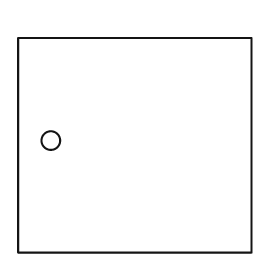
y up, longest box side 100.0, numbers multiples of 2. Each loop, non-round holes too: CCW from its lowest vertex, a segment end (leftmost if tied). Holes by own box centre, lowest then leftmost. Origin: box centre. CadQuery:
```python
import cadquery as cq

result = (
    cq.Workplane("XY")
    .moveTo(-50.0, -46.0)
    .lineTo(50.0, -46.0)
    .lineTo(50.0, 46.0)
    .lineTo(-50.0, 46.0)
    .close()
    .moveTo(-36.0, 2.0)
    .circle(4.0)
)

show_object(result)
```